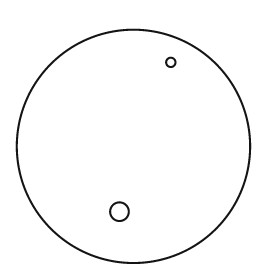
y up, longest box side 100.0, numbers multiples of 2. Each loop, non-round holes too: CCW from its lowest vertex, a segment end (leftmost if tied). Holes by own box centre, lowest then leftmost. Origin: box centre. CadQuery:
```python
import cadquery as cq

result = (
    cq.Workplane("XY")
    .moveTo(0.0, 0.0)
    .circle(50.0)
    .moveTo(-6.0, -28.0)
    .circle(4.0)
    .moveTo(16.0, 36.0)
    .circle(2.0)
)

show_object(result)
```